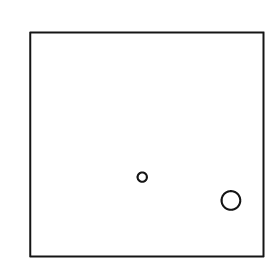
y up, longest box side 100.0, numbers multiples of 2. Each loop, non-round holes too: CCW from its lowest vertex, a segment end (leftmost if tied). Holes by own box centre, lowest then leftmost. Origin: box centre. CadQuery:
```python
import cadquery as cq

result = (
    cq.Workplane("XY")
    .moveTo(-50.0, -48.0)
    .lineTo(50.0, -48.0)
    .lineTo(50.0, 48.0)
    .lineTo(-50.0, 48.0)
    .close()
    .moveTo(36.0, -24.0)
    .circle(4.0)
    .moveTo(-2.0, -14.0)
    .circle(2.0)
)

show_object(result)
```